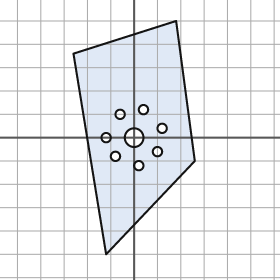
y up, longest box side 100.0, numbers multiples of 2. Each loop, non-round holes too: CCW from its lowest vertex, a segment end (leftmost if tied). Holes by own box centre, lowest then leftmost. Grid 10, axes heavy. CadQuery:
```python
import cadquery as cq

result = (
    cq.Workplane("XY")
    .moveTo(-12.0, -50.0)
    .lineTo(26.0, -10.0)
    .lineTo(18.0, 50.0)
    .lineTo(-26.0, 36.0)
    .close()
    .moveTo(2.0, -12.0)
    .circle(2.0)
    .moveTo(-8.0, -8.0)
    .circle(2.0)
    .moveTo(10.0, -6.0)
    .circle(2.0)
    .moveTo(-12.0, 0.0)
    .circle(2.0)
    .moveTo(0.0, 0.0)
    .circle(4.0)
    .moveTo(12.0, 4.0)
    .circle(2.0)
    .moveTo(-6.0, 10.0)
    .circle(2.0)
    .moveTo(4.0, 12.0)
    .circle(2.0)
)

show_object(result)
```